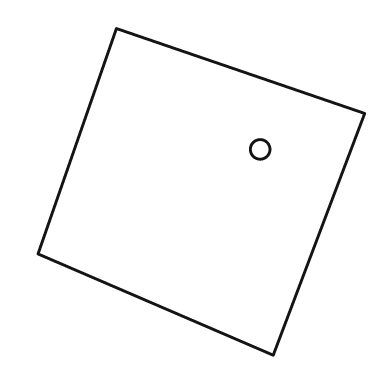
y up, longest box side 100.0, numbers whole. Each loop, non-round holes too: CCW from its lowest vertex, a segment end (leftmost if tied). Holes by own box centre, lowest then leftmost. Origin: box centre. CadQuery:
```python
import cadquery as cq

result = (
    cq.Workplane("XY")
    .moveTo(22.0, -50.0)
    .lineTo(50.0, 24.0)
    .lineTo(-26.0, 50.0)
    .lineTo(-50.0, -19.0)
    .close()
    .moveTo(18.0, 13.0)
    .circle(3.0)
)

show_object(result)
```